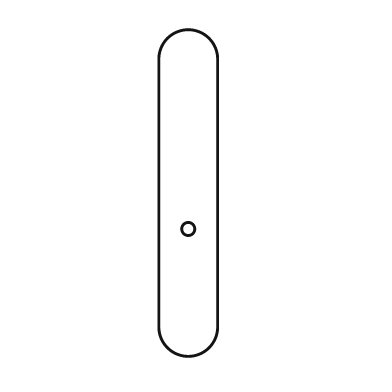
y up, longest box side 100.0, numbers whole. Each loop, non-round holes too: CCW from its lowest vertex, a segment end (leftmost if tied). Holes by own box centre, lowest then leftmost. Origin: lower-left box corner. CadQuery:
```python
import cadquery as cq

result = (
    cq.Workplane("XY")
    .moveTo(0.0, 9.0)
    .threePointArc((9.0, 0.0), (18.0, 9.0))
    .lineTo(18.0, 91.0)
    .threePointArc((9.0, 100.0), (0.0, 91.0))
    .close()
    .moveTo(9.0, 39.0)
    .circle(2.0)
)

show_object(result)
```